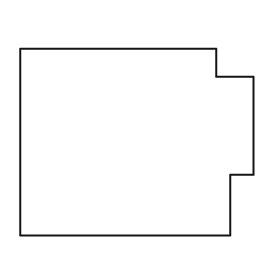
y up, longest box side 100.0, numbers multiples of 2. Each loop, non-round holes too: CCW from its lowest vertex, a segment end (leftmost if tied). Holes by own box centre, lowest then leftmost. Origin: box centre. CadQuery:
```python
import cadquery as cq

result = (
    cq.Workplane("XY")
    .moveTo(-50.0, -40.0)
    .lineTo(40.0, -40.0)
    .lineTo(40.0, -14.0)
    .lineTo(50.0, -14.0)
    .lineTo(50.0, 28.0)
    .lineTo(34.0, 28.0)
    .lineTo(34.0, 40.0)
    .lineTo(-50.0, 40.0)
    .close()
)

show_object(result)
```